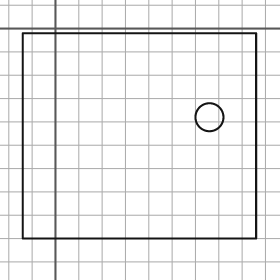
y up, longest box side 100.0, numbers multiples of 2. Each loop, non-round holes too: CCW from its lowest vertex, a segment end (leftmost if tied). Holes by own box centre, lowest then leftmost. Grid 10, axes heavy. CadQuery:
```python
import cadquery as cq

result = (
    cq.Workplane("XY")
    .moveTo(-14.0, -90.0)
    .lineTo(86.0, -90.0)
    .lineTo(86.0, -2.0)
    .lineTo(-14.0, -2.0)
    .close()
    .moveTo(66.0, -38.0)
    .circle(6.0)
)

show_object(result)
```